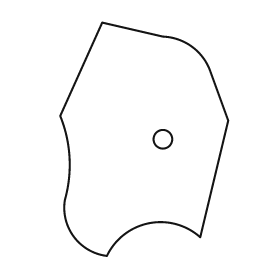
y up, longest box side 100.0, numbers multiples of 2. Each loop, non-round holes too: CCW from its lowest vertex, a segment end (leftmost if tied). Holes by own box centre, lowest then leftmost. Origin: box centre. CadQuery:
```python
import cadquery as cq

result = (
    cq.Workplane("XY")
    .moveTo(-16.0, -50.0)
    .threePointArc((2.0, -36.0), (24.0, -42.0))
    .lineTo(36.0, 8.0)
    .lineTo(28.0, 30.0)
    .threePointArc((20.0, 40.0), (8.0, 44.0))
    .lineTo(-18.0, 50.0)
    .lineTo(-36.0, 10.0)
    .threePointArc((-32.0, -8.0), (-34.0, -26.0))
    .threePointArc((-30.0, -42.0), (-16.0, -50.0))
    .close()
    .moveTo(8.0, 0.0)
    .circle(4.0)
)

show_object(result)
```